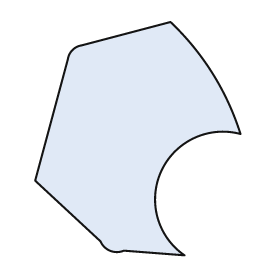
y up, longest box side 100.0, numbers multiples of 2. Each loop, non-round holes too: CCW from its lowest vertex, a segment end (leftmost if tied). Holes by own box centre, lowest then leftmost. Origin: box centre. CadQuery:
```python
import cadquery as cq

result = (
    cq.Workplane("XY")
    .moveTo(20.0, -50.0)
    .threePointArc((10.0, -14.0), (44.0, 2.0))
    .threePointArc((32.0, 28.0), (14.0, 50.0))
    .lineTo(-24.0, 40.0)
    .threePointArc((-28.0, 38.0), (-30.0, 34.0))
    .lineTo(-44.0, -18.0)
    .lineTo(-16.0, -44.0)
    .threePointArc((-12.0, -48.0), (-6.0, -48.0))
    .close()
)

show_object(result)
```